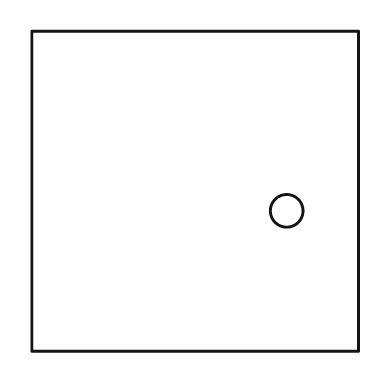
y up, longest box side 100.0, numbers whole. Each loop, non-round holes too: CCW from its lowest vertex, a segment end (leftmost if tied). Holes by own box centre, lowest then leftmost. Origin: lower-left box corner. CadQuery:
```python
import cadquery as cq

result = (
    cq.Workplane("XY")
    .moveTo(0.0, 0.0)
    .lineTo(100.0, 0.0)
    .lineTo(100.0, 98.0)
    .lineTo(0.0, 98.0)
    .close()
    .moveTo(78.0, 43.0)
    .circle(5.0)
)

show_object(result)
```